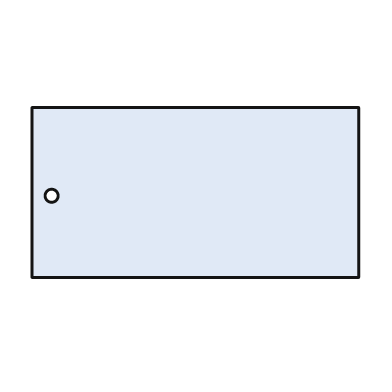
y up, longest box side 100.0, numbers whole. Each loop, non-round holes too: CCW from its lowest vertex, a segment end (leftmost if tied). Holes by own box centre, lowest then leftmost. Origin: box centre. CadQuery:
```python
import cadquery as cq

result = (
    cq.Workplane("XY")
    .moveTo(-50.0, -26.0)
    .lineTo(50.0, -26.0)
    .lineTo(50.0, 26.0)
    .lineTo(-50.0, 26.0)
    .close()
    .moveTo(-44.0, -1.0)
    .circle(2.0)
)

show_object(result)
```